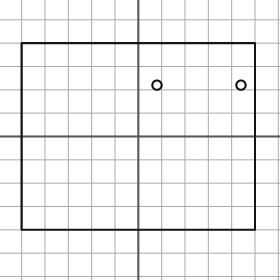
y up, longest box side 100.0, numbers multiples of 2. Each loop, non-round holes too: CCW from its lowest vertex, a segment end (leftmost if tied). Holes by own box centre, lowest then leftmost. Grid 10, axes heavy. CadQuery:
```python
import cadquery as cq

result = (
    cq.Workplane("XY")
    .moveTo(-50.0, -40.0)
    .lineTo(50.0, -40.0)
    .lineTo(50.0, 40.0)
    .lineTo(-50.0, 40.0)
    .close()
    .moveTo(8.0, 22.0)
    .circle(2.0)
    .moveTo(44.0, 22.0)
    .circle(2.0)
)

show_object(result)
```